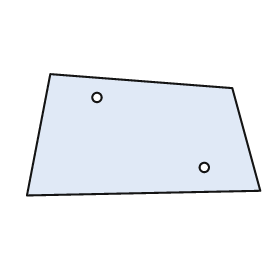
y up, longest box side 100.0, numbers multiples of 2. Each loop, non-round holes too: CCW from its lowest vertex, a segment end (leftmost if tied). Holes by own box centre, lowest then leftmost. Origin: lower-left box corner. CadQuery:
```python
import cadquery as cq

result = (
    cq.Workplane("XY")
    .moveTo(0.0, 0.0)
    .lineTo(100.0, 2.0)
    .lineTo(88.0, 46.0)
    .lineTo(10.0, 52.0)
    .close()
    .moveTo(76.0, 12.0)
    .circle(2.0)
    .moveTo(30.0, 42.0)
    .circle(2.0)
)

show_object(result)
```